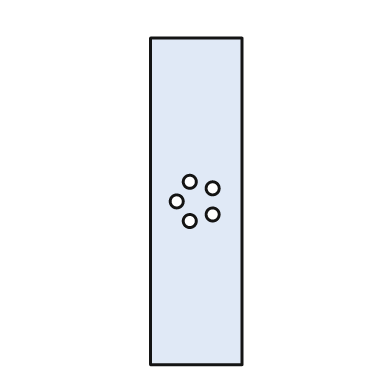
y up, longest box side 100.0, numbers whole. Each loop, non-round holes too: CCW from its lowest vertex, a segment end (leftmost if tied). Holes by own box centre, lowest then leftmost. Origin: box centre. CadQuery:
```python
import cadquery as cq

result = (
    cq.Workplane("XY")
    .moveTo(-14.0, -50.0)
    .lineTo(14.0, -50.0)
    .lineTo(14.0, 50.0)
    .lineTo(-14.0, 50.0)
    .close()
    .moveTo(-2.0, -6.0)
    .circle(2.0)
    .moveTo(5.0, -4.0)
    .circle(2.0)
    .moveTo(-6.0, 0.0)
    .circle(2.0)
    .moveTo(5.0, 4.0)
    .circle(2.0)
    .moveTo(-2.0, 6.0)
    .circle(2.0)
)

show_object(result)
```